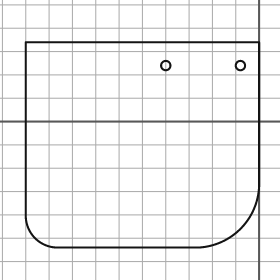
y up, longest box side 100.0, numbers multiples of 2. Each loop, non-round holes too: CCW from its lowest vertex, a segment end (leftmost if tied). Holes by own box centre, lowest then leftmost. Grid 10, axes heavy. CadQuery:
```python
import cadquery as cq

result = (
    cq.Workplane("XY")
    .moveTo(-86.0, -54.0)
    .lineTo(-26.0, -54.0)
    .threePointArc((-8.0, -46.0), (0.0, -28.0))
    .lineTo(0.0, 34.0)
    .lineTo(-100.0, 34.0)
    .lineTo(-100.0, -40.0)
    .threePointArc((-96.0, -50.0), (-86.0, -54.0))
    .close()
    .moveTo(-40.0, 24.0)
    .circle(2.0)
    .moveTo(-8.0, 24.0)
    .circle(2.0)
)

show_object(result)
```